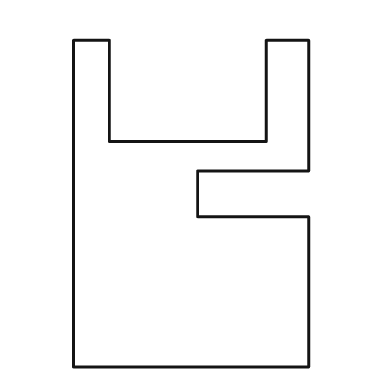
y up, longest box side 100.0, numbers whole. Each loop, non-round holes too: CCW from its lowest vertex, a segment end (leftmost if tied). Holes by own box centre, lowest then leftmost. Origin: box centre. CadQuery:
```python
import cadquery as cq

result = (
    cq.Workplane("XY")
    .moveTo(-36.0, -50.0)
    .lineTo(36.0, -50.0)
    .lineTo(36.0, -4.0)
    .lineTo(2.0, -4.0)
    .lineTo(2.0, 10.0)
    .lineTo(36.0, 10.0)
    .lineTo(36.0, 50.0)
    .lineTo(23.0, 50.0)
    .lineTo(23.0, 19.0)
    .lineTo(-25.0, 19.0)
    .lineTo(-25.0, 50.0)
    .lineTo(-36.0, 50.0)
    .close()
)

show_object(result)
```